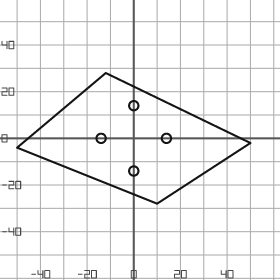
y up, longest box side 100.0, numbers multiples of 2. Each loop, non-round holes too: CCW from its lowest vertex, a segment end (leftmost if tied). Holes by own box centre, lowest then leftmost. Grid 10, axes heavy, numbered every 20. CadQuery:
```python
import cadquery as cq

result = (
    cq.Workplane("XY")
    .moveTo(10.0, -28.0)
    .lineTo(50.0, -2.0)
    .lineTo(-12.0, 28.0)
    .lineTo(-50.0, -4.0)
    .close()
    .moveTo(0.0, -14.0)
    .circle(2.0)
    .moveTo(-14.0, 0.0)
    .circle(2.0)
    .moveTo(14.0, 0.0)
    .circle(2.0)
    .moveTo(0.0, 14.0)
    .circle(2.0)
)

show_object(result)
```